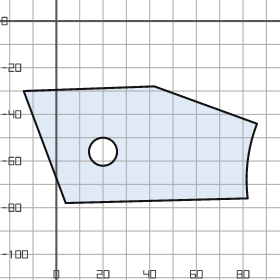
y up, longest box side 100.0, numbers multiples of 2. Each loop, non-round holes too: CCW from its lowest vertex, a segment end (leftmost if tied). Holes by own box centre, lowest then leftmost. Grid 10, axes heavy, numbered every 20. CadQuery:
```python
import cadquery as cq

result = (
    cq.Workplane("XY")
    .moveTo(4.0, -78.0)
    .lineTo(82.0, -76.0)
    .threePointArc((82.0, -60.0), (86.0, -44.0))
    .lineTo(42.0, -28.0)
    .lineTo(-14.0, -30.0)
    .close()
    .moveTo(20.0, -56.0)
    .circle(6.0)
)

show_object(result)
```